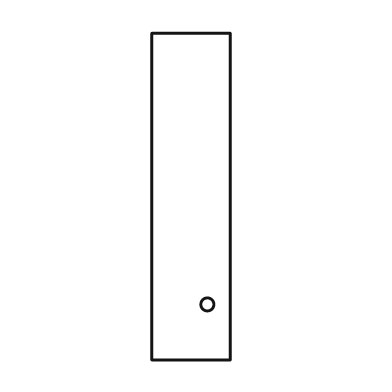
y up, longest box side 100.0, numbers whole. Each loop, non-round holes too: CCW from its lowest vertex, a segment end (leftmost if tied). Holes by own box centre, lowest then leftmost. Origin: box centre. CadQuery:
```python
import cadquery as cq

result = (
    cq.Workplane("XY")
    .moveTo(-12.0, -50.0)
    .lineTo(12.0, -50.0)
    .lineTo(12.0, 50.0)
    .lineTo(-12.0, 50.0)
    .close()
    .moveTo(5.0, -33.0)
    .circle(2.0)
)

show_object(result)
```